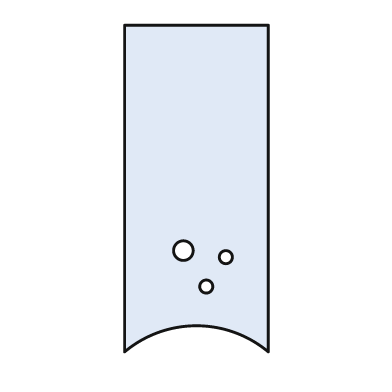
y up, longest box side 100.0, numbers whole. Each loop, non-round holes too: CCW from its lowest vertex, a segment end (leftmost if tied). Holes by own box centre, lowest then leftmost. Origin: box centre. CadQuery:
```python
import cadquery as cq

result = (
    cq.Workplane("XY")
    .moveTo(-22.0, -50.0)
    .threePointArc((0.0, -42.0), (22.0, -50.0))
    .lineTo(22.0, 50.0)
    .lineTo(-22.0, 50.0)
    .close()
    .moveTo(3.0, -30.0)
    .circle(2.0)
    .moveTo(9.0, -21.0)
    .circle(2.0)
    .moveTo(-4.0, -19.0)
    .circle(3.0)
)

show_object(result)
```